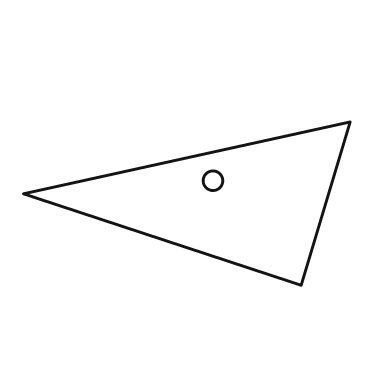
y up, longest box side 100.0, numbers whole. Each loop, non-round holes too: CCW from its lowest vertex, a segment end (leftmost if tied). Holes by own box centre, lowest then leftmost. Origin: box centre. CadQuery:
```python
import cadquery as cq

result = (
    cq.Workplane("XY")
    .moveTo(35.0, -25.0)
    .lineTo(50.0, 25.0)
    .lineTo(-50.0, 3.0)
    .close()
    .moveTo(8.0, 7.0)
    .circle(3.0)
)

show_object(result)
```